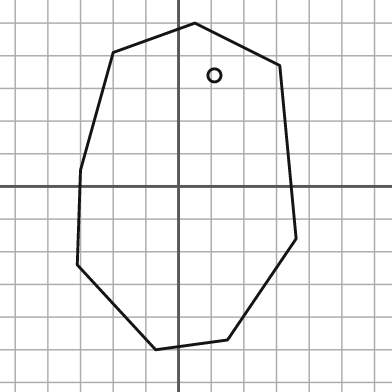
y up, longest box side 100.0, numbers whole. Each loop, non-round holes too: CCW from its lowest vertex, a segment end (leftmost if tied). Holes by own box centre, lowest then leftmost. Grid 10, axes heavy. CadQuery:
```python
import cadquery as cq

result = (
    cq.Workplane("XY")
    .moveTo(-7.0, -50.0)
    .lineTo(15.0, -47.0)
    .lineTo(36.0, -16.0)
    .lineTo(31.0, 37.0)
    .lineTo(5.0, 50.0)
    .lineTo(-20.0, 41.0)
    .lineTo(-30.0, 5.0)
    .lineTo(-31.0, -24.0)
    .close()
    .moveTo(11.0, 34.0)
    .circle(2.0)
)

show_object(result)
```